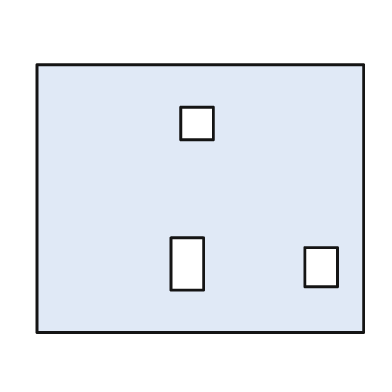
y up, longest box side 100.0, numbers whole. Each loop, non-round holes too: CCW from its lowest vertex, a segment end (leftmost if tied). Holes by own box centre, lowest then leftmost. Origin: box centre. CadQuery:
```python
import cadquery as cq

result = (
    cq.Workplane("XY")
    .moveTo(-50.0, -41.0)
    .lineTo(50.0, -41.0)
    .lineTo(50.0, 41.0)
    .lineTo(-50.0, 41.0)
    .close()
    .moveTo(32.0, -27.0)
    .lineTo(42.0, -27.0)
    .lineTo(42.0, -15.0)
    .lineTo(32.0, -15.0)
    .close()
    .moveTo(-9.0, -28.0)
    .lineTo(1.0, -28.0)
    .lineTo(1.0, -12.0)
    .lineTo(-9.0, -12.0)
    .close()
    .moveTo(-6.0, 18.0)
    .lineTo(4.0, 18.0)
    .lineTo(4.0, 28.0)
    .lineTo(-6.0, 28.0)
    .close()
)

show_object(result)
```